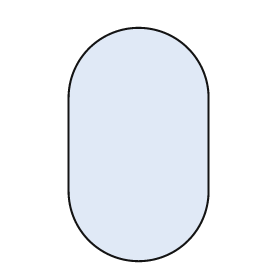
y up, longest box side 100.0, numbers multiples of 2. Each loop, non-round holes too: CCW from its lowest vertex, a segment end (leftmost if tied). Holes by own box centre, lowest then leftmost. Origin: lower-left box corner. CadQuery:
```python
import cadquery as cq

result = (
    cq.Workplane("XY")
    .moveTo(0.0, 30.0)
    .threePointArc((30.0, 0.0), (60.0, 30.0))
    .lineTo(60.0, 70.0)
    .threePointArc((30.0, 100.0), (0.0, 70.0))
    .close()
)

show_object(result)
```